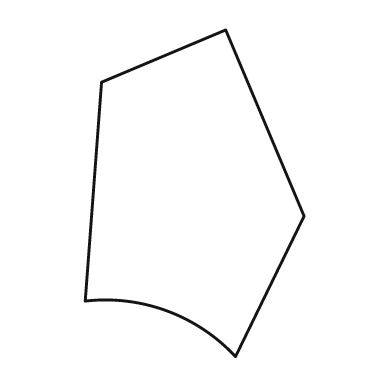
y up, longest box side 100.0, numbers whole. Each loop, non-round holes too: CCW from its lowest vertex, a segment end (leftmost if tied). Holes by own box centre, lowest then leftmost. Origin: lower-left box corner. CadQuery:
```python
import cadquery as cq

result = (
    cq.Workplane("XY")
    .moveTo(46.0, 0.0)
    .lineTo(67.0, 43.0)
    .lineTo(43.0, 100.0)
    .lineTo(5.0, 84.0)
    .lineTo(0.0, 17.0)
    .threePointArc((25.0, 14.0), (46.0, 0.0))
    .close()
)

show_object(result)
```